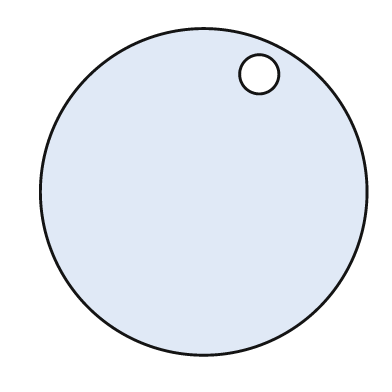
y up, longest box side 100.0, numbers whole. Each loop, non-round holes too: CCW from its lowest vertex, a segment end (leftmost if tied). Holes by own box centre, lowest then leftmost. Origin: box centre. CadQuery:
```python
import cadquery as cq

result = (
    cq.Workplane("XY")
    .moveTo(0.0, 0.0)
    .circle(50.0)
    .moveTo(17.0, 36.0)
    .circle(6.0)
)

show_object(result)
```